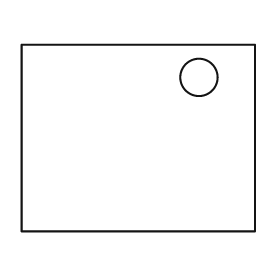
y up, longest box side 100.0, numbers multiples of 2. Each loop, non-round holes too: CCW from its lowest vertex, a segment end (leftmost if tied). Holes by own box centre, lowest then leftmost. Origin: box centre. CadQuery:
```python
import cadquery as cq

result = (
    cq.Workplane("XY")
    .moveTo(-50.0, -40.0)
    .lineTo(50.0, -40.0)
    .lineTo(50.0, 40.0)
    .lineTo(-50.0, 40.0)
    .close()
    .moveTo(26.0, 26.0)
    .circle(8.0)
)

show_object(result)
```